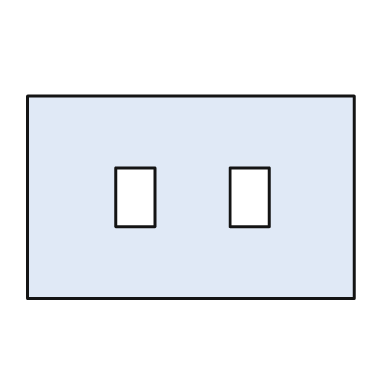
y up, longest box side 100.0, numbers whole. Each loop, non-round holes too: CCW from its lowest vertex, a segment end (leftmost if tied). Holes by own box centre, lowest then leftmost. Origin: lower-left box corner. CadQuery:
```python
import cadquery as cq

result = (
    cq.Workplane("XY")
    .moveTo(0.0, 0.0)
    .lineTo(100.0, 0.0)
    .lineTo(100.0, 62.0)
    .lineTo(0.0, 62.0)
    .close()
    .moveTo(27.0, 22.0)
    .lineTo(39.0, 22.0)
    .lineTo(39.0, 40.0)
    .lineTo(27.0, 40.0)
    .close()
    .moveTo(62.0, 22.0)
    .lineTo(74.0, 22.0)
    .lineTo(74.0, 40.0)
    .lineTo(62.0, 40.0)
    .close()
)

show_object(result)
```